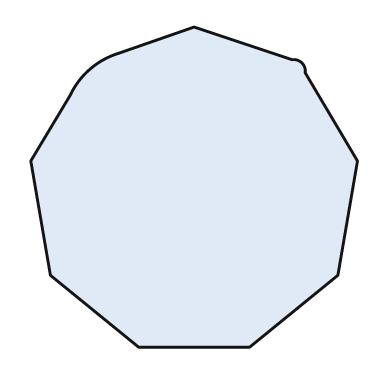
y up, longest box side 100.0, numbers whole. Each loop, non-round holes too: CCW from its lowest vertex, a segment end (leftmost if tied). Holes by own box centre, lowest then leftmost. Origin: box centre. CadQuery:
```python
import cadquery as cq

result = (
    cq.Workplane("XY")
    .moveTo(-17.0, -49.0)
    .lineTo(17.0, -49.0)
    .lineTo(44.0, -27.0)
    .lineTo(50.0, 8.0)
    .lineTo(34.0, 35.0)
    .threePointArc((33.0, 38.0), (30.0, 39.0))
    .lineTo(0.0, 49.0)
    .lineTo(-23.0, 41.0)
    .threePointArc((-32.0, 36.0), (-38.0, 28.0))
    .lineTo(-50.0, 8.0)
    .lineTo(-44.0, -27.0)
    .close()
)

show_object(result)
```